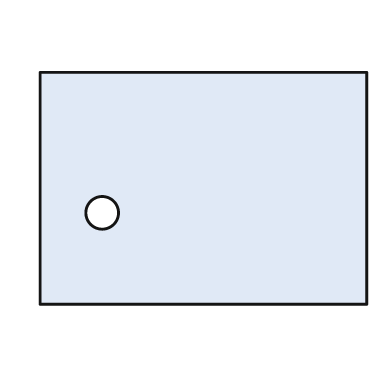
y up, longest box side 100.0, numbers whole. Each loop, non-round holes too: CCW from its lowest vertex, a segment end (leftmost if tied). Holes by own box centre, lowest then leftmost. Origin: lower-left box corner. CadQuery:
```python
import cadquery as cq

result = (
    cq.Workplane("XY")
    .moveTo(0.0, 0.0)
    .lineTo(100.0, 0.0)
    .lineTo(100.0, 71.0)
    .lineTo(0.0, 71.0)
    .close()
    .moveTo(19.0, 28.0)
    .circle(5.0)
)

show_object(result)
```